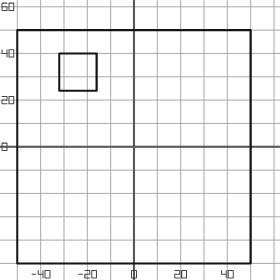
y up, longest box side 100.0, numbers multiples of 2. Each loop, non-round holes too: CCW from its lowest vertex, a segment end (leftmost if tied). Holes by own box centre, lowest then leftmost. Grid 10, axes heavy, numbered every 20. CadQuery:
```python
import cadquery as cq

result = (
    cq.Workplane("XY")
    .moveTo(-50.0, -50.0)
    .lineTo(50.0, -50.0)
    .lineTo(50.0, 50.0)
    .lineTo(-50.0, 50.0)
    .close()
    .moveTo(-32.0, 24.0)
    .lineTo(-16.0, 24.0)
    .lineTo(-16.0, 40.0)
    .lineTo(-32.0, 40.0)
    .close()
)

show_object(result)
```